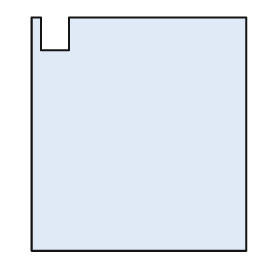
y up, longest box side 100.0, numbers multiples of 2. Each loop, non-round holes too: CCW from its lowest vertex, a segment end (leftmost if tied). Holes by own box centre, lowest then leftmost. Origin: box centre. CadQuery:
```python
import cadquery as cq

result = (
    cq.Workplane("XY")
    .moveTo(-46.0, -50.0)
    .lineTo(46.0, -50.0)
    .lineTo(46.0, 50.0)
    .lineTo(-30.0, 50.0)
    .lineTo(-30.0, 36.0)
    .lineTo(-42.0, 36.0)
    .lineTo(-42.0, 50.0)
    .lineTo(-46.0, 50.0)
    .close()
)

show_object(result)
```